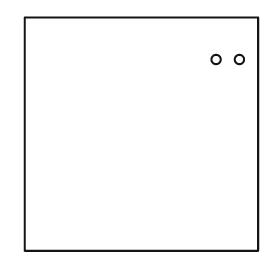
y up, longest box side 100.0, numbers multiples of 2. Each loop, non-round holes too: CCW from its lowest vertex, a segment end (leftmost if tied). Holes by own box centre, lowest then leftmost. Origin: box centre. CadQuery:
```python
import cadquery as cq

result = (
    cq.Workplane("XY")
    .moveTo(-50.0, -50.0)
    .lineTo(50.0, -50.0)
    .lineTo(50.0, 50.0)
    .lineTo(-50.0, 50.0)
    .close()
    .moveTo(32.0, 32.0)
    .circle(2.0)
    .moveTo(42.0, 32.0)
    .circle(2.0)
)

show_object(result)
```